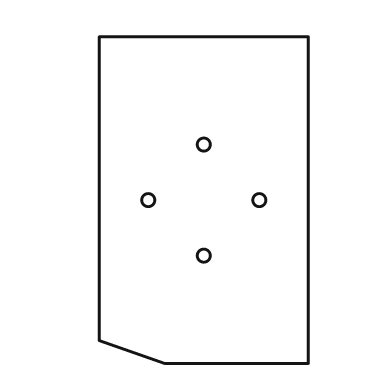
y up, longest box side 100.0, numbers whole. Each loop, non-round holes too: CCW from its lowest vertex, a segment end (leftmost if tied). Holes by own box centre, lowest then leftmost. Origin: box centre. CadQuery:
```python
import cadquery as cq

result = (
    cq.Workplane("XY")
    .moveTo(-12.0, -50.0)
    .lineTo(32.0, -50.0)
    .lineTo(32.0, 50.0)
    .lineTo(-32.0, 50.0)
    .lineTo(-32.0, -43.0)
    .close()
    .moveTo(0.0, -17.0)
    .circle(2.0)
    .moveTo(-17.0, 0.0)
    .circle(2.0)
    .moveTo(17.0, 0.0)
    .circle(2.0)
    .moveTo(0.0, 17.0)
    .circle(2.0)
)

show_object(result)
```